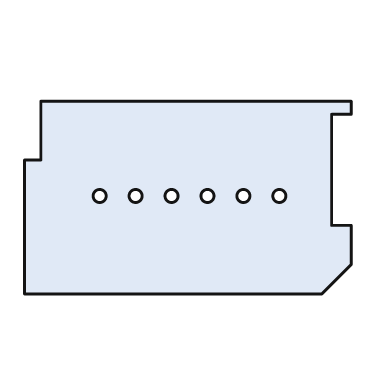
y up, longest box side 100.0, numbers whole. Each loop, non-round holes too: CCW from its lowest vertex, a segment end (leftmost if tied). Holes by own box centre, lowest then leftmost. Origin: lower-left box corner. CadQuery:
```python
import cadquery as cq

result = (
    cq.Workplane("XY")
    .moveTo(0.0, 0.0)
    .lineTo(91.0, 0.0)
    .lineTo(100.0, 9.0)
    .lineTo(100.0, 21.0)
    .lineTo(94.0, 21.0)
    .lineTo(94.0, 55.0)
    .lineTo(100.0, 55.0)
    .lineTo(100.0, 59.0)
    .lineTo(5.0, 59.0)
    .lineTo(5.0, 41.0)
    .lineTo(0.0, 41.0)
    .close()
    .moveTo(23.0, 30.0)
    .circle(2.0)
    .moveTo(34.0, 30.0)
    .circle(2.0)
    .moveTo(45.0, 30.0)
    .circle(2.0)
    .moveTo(56.0, 30.0)
    .circle(2.0)
    .moveTo(67.0, 30.0)
    .circle(2.0)
    .moveTo(78.0, 30.0)
    .circle(2.0)
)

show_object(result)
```